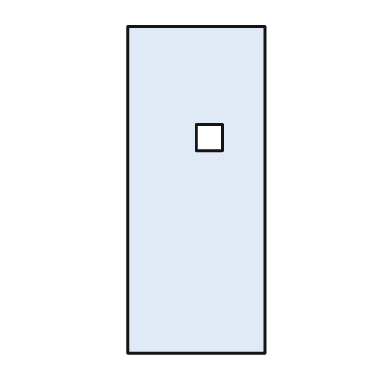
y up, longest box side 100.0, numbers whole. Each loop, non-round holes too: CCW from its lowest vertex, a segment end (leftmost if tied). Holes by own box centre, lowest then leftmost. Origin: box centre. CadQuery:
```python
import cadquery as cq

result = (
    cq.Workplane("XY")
    .moveTo(-21.0, -50.0)
    .lineTo(21.0, -50.0)
    .lineTo(21.0, 50.0)
    .lineTo(-21.0, 50.0)
    .close()
    .moveTo(0.0, 12.0)
    .lineTo(8.0, 12.0)
    .lineTo(8.0, 20.0)
    .lineTo(0.0, 20.0)
    .close()
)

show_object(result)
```